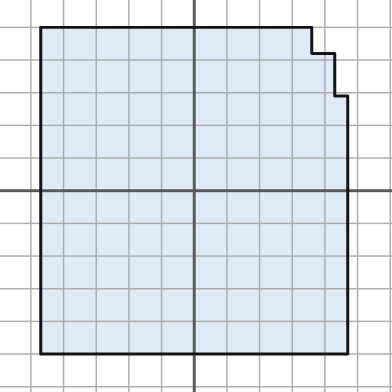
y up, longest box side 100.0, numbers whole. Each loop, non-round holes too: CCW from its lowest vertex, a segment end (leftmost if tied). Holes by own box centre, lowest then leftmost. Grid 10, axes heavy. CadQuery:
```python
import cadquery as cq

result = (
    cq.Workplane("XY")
    .moveTo(-47.0, -50.0)
    .lineTo(47.0, -50.0)
    .lineTo(47.0, 29.0)
    .lineTo(43.0, 29.0)
    .lineTo(43.0, 42.0)
    .lineTo(36.0, 42.0)
    .lineTo(36.0, 50.0)
    .lineTo(-47.0, 50.0)
    .close()
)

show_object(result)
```